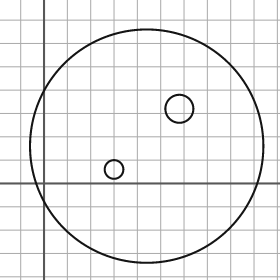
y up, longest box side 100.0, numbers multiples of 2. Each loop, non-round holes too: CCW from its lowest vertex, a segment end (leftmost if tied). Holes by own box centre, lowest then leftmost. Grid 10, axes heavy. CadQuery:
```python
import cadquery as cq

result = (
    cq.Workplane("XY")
    .moveTo(44.0, 16.0)
    .circle(50.0)
    .moveTo(30.0, 6.0)
    .circle(4.0)
    .moveTo(58.0, 32.0)
    .circle(6.0)
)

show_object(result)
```